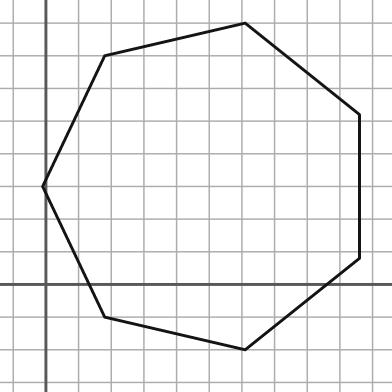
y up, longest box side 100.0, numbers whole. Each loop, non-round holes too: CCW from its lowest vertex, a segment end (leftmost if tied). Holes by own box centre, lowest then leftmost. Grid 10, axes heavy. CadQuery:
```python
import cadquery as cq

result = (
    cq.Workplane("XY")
    .moveTo(61.0, -20.0)
    .lineTo(96.0, 8.0)
    .lineTo(96.0, 52.0)
    .lineTo(61.0, 80.0)
    .lineTo(18.0, 70.0)
    .lineTo(-1.0, 30.0)
    .lineTo(18.0, -10.0)
    .close()
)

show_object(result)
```